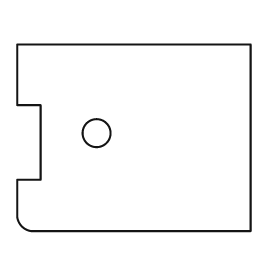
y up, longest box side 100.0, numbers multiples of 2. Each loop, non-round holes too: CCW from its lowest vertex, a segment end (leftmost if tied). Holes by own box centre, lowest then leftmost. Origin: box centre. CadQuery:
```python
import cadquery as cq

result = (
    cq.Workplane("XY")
    .moveTo(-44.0, -40.0)
    .lineTo(50.0, -40.0)
    .lineTo(50.0, 40.0)
    .lineTo(-50.0, 40.0)
    .lineTo(-50.0, 14.0)
    .lineTo(-40.0, 14.0)
    .lineTo(-40.0, -18.0)
    .lineTo(-50.0, -18.0)
    .lineTo(-50.0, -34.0)
    .threePointArc((-48.0, -38.0), (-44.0, -40.0))
    .close()
    .moveTo(-16.0, 2.0)
    .circle(6.0)
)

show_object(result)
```